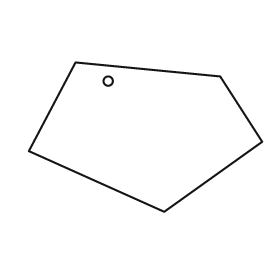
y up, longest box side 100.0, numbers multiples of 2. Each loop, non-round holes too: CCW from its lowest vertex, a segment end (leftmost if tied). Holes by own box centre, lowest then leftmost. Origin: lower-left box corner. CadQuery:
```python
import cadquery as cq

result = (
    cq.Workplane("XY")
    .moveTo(58.0, 0.0)
    .lineTo(100.0, 30.0)
    .lineTo(82.0, 58.0)
    .lineTo(20.0, 64.0)
    .lineTo(0.0, 26.0)
    .close()
    .moveTo(34.0, 56.0)
    .circle(2.0)
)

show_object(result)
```